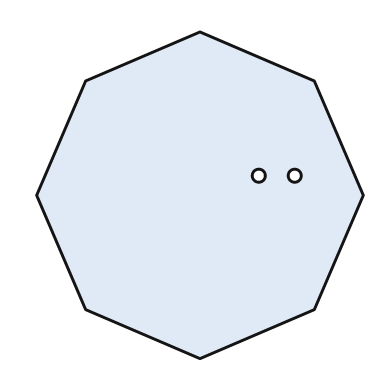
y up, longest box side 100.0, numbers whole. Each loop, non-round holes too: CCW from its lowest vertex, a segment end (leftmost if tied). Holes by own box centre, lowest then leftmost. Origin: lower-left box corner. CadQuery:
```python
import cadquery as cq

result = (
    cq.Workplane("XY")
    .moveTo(50.0, 0.0)
    .lineTo(85.0, 15.0)
    .lineTo(100.0, 50.0)
    .lineTo(85.0, 85.0)
    .lineTo(50.0, 100.0)
    .lineTo(15.0, 85.0)
    .lineTo(0.0, 50.0)
    .lineTo(15.0, 15.0)
    .close()
    .moveTo(68.0, 56.0)
    .circle(2.0)
    .moveTo(79.0, 56.0)
    .circle(2.0)
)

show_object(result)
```